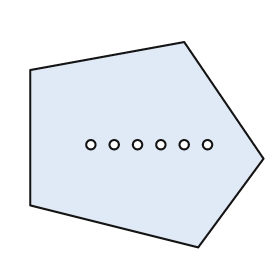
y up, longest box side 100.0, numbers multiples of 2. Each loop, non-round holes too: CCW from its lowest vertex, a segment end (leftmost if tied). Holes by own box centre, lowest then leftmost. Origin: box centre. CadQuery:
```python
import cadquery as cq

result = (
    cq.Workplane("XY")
    .moveTo(22.0, -44.0)
    .lineTo(50.0, -6.0)
    .lineTo(16.0, 44.0)
    .lineTo(-50.0, 32.0)
    .lineTo(-50.0, -26.0)
    .close()
    .moveTo(-24.0, 0.0)
    .circle(2.0)
    .moveTo(-14.0, 0.0)
    .circle(2.0)
    .moveTo(-4.0, 0.0)
    .circle(2.0)
    .moveTo(6.0, 0.0)
    .circle(2.0)
    .moveTo(16.0, 0.0)
    .circle(2.0)
    .moveTo(26.0, 0.0)
    .circle(2.0)
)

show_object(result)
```